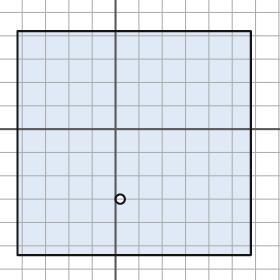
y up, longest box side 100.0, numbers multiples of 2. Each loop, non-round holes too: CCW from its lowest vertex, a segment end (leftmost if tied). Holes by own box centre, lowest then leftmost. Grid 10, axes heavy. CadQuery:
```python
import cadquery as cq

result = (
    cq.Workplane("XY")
    .moveTo(-42.0, -54.0)
    .lineTo(58.0, -54.0)
    .lineTo(58.0, 42.0)
    .lineTo(-42.0, 42.0)
    .close()
    .moveTo(2.0, -30.0)
    .circle(2.0)
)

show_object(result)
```